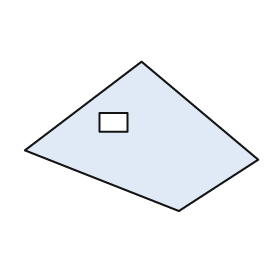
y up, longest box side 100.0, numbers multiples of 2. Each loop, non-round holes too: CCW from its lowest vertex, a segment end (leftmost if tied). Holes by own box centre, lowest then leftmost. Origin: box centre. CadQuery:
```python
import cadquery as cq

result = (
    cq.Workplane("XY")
    .moveTo(16.0, -32.0)
    .lineTo(50.0, -10.0)
    .lineTo(0.0, 32.0)
    .lineTo(-50.0, -6.0)
    .close()
    .moveTo(-18.0, 2.0)
    .lineTo(-6.0, 2.0)
    .lineTo(-6.0, 10.0)
    .lineTo(-18.0, 10.0)
    .close()
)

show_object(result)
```